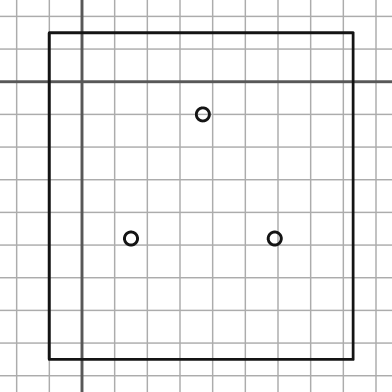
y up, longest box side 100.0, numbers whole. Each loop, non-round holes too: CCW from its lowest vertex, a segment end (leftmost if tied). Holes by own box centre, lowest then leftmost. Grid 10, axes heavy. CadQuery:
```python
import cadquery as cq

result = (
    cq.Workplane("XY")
    .moveTo(-10.0, -85.0)
    .lineTo(83.0, -85.0)
    .lineTo(83.0, 15.0)
    .lineTo(-10.0, 15.0)
    .close()
    .moveTo(15.0, -48.0)
    .circle(2.0)
    .moveTo(59.0, -48.0)
    .circle(2.0)
    .moveTo(37.0, -10.0)
    .circle(2.0)
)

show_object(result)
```